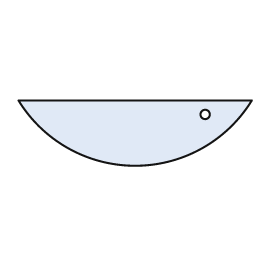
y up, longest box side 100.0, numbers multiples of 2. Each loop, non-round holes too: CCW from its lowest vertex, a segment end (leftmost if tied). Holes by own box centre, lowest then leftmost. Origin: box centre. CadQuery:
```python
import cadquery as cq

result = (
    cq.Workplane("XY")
    .moveTo(-50.0, 14.0)
    .threePointArc((0.0, -14.0), (50.0, 14.0))
    .close()
    .moveTo(30.0, 8.0)
    .circle(2.0)
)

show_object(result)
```